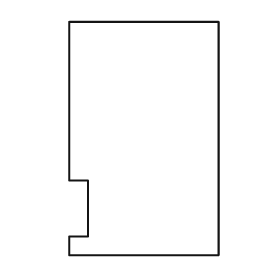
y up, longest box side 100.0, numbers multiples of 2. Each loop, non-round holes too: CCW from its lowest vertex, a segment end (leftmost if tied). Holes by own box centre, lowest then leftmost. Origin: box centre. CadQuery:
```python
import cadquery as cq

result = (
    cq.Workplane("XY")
    .moveTo(-32.0, -50.0)
    .lineTo(32.0, -50.0)
    .lineTo(32.0, 50.0)
    .lineTo(-32.0, 50.0)
    .lineTo(-32.0, -18.0)
    .lineTo(-24.0, -18.0)
    .lineTo(-24.0, -42.0)
    .lineTo(-32.0, -42.0)
    .close()
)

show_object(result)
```